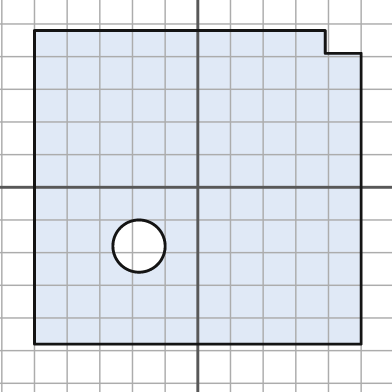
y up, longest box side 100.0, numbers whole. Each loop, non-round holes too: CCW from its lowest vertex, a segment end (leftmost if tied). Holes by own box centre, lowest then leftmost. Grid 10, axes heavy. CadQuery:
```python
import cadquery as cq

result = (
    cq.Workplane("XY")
    .moveTo(-50.0, -48.0)
    .lineTo(50.0, -48.0)
    .lineTo(50.0, 41.0)
    .lineTo(39.0, 41.0)
    .lineTo(39.0, 48.0)
    .lineTo(-50.0, 48.0)
    .close()
    .moveTo(-18.0, -18.0)
    .circle(8.0)
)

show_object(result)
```